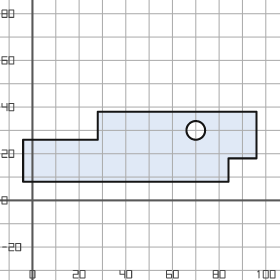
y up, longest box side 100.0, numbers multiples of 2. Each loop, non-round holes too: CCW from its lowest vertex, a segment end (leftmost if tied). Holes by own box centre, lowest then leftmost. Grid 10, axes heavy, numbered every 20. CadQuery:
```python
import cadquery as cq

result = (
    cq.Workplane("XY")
    .moveTo(-4.0, 8.0)
    .lineTo(84.0, 8.0)
    .lineTo(84.0, 18.0)
    .lineTo(96.0, 18.0)
    .lineTo(96.0, 38.0)
    .lineTo(28.0, 38.0)
    .lineTo(28.0, 26.0)
    .lineTo(-4.0, 26.0)
    .close()
    .moveTo(70.0, 30.0)
    .circle(4.0)
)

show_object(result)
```